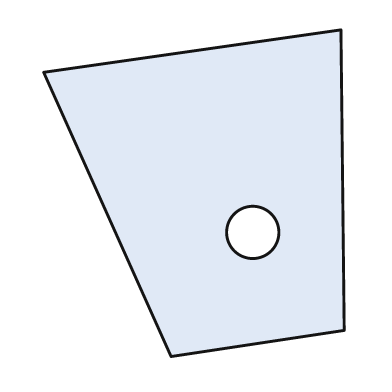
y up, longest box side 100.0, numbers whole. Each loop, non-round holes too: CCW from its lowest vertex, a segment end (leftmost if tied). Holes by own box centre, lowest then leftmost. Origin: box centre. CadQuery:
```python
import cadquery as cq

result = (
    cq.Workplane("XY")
    .moveTo(-7.0, -50.0)
    .lineTo(46.0, -42.0)
    .lineTo(45.0, 50.0)
    .lineTo(-46.0, 37.0)
    .close()
    .moveTo(18.0, -12.0)
    .circle(8.0)
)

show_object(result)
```